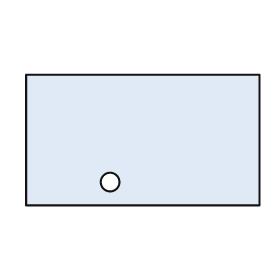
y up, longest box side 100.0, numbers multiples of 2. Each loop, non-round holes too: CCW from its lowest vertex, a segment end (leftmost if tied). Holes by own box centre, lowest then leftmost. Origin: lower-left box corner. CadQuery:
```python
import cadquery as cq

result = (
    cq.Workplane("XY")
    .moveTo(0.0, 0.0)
    .lineTo(100.0, 0.0)
    .lineTo(100.0, 56.0)
    .lineTo(0.0, 56.0)
    .close()
    .moveTo(36.0, 10.0)
    .circle(4.0)
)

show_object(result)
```